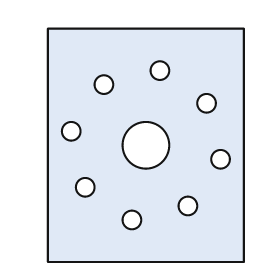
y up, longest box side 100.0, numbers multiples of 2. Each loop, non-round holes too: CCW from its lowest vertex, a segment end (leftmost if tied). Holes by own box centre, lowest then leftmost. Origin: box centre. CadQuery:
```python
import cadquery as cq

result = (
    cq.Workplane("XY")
    .moveTo(-42.0, -50.0)
    .lineTo(42.0, -50.0)
    .lineTo(42.0, 50.0)
    .lineTo(-42.0, 50.0)
    .close()
    .moveTo(-6.0, -32.0)
    .circle(4.0)
    .moveTo(18.0, -26.0)
    .circle(4.0)
    .moveTo(-26.0, -18.0)
    .circle(4.0)
    .moveTo(32.0, -6.0)
    .circle(4.0)
    .moveTo(0.0, 0.0)
    .circle(10.0)
    .moveTo(-32.0, 6.0)
    .circle(4.0)
    .moveTo(26.0, 18.0)
    .circle(4.0)
    .moveTo(-18.0, 26.0)
    .circle(4.0)
    .moveTo(6.0, 32.0)
    .circle(4.0)
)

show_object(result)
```